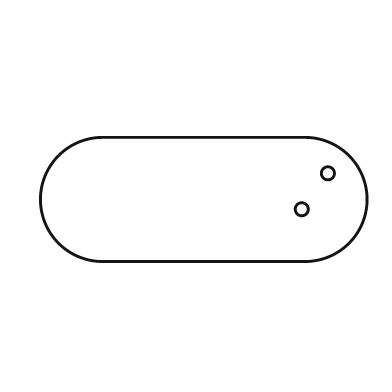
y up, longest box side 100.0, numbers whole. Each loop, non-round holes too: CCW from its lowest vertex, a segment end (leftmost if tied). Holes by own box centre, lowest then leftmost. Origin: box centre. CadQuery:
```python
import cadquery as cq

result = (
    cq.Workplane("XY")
    .moveTo(-31.0, -19.0)
    .lineTo(31.0, -19.0)
    .threePointArc((50.0, 0.0), (31.0, 19.0))
    .lineTo(-31.0, 19.0)
    .threePointArc((-50.0, 0.0), (-31.0, -19.0))
    .close()
    .moveTo(30.0, -3.0)
    .circle(2.0)
    .moveTo(38.0, 8.0)
    .circle(2.0)
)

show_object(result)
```